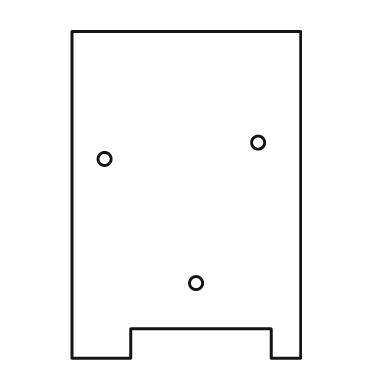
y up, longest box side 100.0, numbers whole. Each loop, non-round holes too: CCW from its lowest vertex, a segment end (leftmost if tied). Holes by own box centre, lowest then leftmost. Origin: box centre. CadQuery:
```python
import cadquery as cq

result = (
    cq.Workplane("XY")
    .moveTo(-35.0, -50.0)
    .lineTo(-17.0, -50.0)
    .lineTo(-17.0, -41.0)
    .lineTo(26.0, -41.0)
    .lineTo(26.0, -50.0)
    .lineTo(35.0, -50.0)
    .lineTo(35.0, 50.0)
    .lineTo(-35.0, 50.0)
    .close()
    .moveTo(3.0, -27.0)
    .circle(2.0)
    .moveTo(-25.0, 11.0)
    .circle(2.0)
    .moveTo(22.0, 16.0)
    .circle(2.0)
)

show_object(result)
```